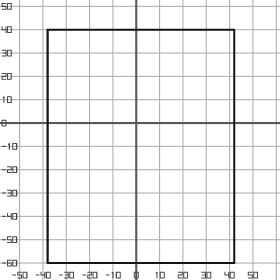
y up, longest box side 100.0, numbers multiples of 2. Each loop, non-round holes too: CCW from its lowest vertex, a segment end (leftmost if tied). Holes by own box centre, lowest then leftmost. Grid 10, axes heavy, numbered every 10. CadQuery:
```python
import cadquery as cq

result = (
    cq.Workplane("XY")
    .moveTo(-38.0, -60.0)
    .lineTo(42.0, -60.0)
    .lineTo(42.0, 40.0)
    .lineTo(-38.0, 40.0)
    .close()
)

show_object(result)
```